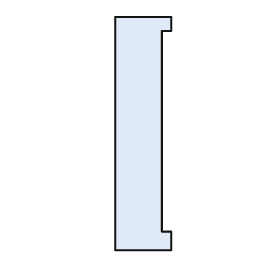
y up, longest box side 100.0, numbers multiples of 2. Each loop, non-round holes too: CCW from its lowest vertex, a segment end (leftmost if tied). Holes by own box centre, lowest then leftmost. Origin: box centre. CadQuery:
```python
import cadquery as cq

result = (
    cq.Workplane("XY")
    .moveTo(-12.0, -50.0)
    .lineTo(12.0, -50.0)
    .lineTo(12.0, -42.0)
    .lineTo(8.0, -42.0)
    .lineTo(8.0, 44.0)
    .lineTo(12.0, 44.0)
    .lineTo(12.0, 50.0)
    .lineTo(-12.0, 50.0)
    .close()
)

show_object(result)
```